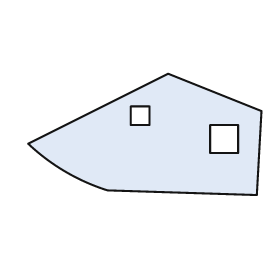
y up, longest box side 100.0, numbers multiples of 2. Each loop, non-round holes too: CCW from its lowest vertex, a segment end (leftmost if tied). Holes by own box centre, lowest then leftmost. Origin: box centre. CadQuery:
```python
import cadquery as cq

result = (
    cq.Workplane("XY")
    .moveTo(48.0, -26.0)
    .lineTo(50.0, 10.0)
    .lineTo(10.0, 26.0)
    .lineTo(-50.0, -4.0)
    .threePointArc((-34.0, -16.0), (-16.0, -24.0))
    .close()
    .moveTo(28.0, -8.0)
    .lineTo(40.0, -8.0)
    .lineTo(40.0, 4.0)
    .lineTo(28.0, 4.0)
    .close()
    .moveTo(-6.0, 4.0)
    .lineTo(2.0, 4.0)
    .lineTo(2.0, 12.0)
    .lineTo(-6.0, 12.0)
    .close()
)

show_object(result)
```